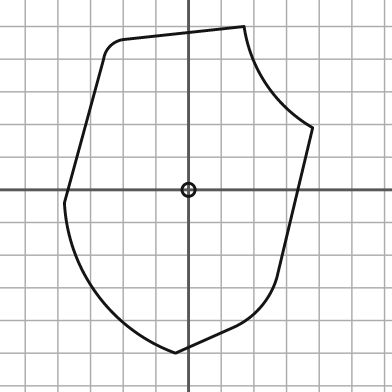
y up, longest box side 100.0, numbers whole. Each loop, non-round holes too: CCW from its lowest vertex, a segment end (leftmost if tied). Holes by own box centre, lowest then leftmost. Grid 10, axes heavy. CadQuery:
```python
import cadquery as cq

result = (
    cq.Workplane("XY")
    .moveTo(-4.0, -50.0)
    .lineTo(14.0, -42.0)
    .threePointArc((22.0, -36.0), (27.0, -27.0))
    .lineTo(38.0, 19.0)
    .threePointArc((24.0, 32.0), (17.0, 50.0))
    .lineTo(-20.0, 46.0)
    .threePointArc((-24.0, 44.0), (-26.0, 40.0))
    .lineTo(-38.0, -4.0)
    .threePointArc((-28.0, -32.0), (-4.0, -50.0))
    .close()
    .moveTo(0.0, 0.0)
    .circle(2.0)
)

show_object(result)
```